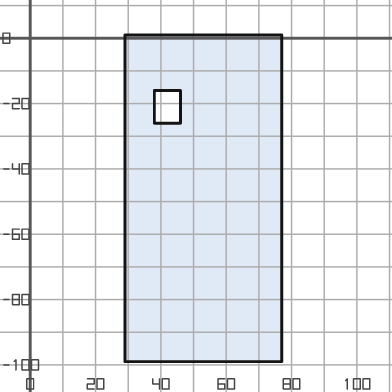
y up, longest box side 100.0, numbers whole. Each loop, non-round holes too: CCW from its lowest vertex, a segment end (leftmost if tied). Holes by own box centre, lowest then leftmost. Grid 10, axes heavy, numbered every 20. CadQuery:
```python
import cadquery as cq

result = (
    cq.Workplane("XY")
    .moveTo(29.0, -99.0)
    .lineTo(77.0, -99.0)
    .lineTo(77.0, 1.0)
    .lineTo(29.0, 1.0)
    .close()
    .moveTo(38.0, -26.0)
    .lineTo(46.0, -26.0)
    .lineTo(46.0, -16.0)
    .lineTo(38.0, -16.0)
    .close()
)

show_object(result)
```